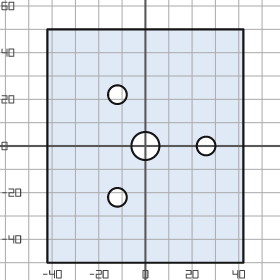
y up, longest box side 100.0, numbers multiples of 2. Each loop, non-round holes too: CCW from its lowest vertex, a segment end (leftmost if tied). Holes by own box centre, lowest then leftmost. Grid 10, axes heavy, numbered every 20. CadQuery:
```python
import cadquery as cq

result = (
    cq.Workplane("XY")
    .moveTo(-42.0, -50.0)
    .lineTo(42.0, -50.0)
    .lineTo(42.0, 50.0)
    .lineTo(-42.0, 50.0)
    .close()
    .moveTo(-12.0, -22.0)
    .circle(4.0)
    .moveTo(0.0, 0.0)
    .circle(6.0)
    .moveTo(26.0, 0.0)
    .circle(4.0)
    .moveTo(-12.0, 22.0)
    .circle(4.0)
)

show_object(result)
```